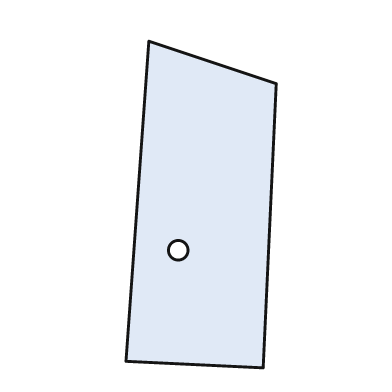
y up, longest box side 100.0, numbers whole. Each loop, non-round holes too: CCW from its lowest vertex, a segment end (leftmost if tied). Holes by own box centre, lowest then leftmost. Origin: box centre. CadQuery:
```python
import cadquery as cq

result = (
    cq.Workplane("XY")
    .moveTo(19.0, -50.0)
    .lineTo(23.0, 37.0)
    .lineTo(-16.0, 50.0)
    .lineTo(-23.0, -48.0)
    .close()
    .moveTo(-7.0, -14.0)
    .circle(3.0)
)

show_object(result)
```